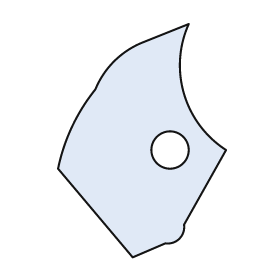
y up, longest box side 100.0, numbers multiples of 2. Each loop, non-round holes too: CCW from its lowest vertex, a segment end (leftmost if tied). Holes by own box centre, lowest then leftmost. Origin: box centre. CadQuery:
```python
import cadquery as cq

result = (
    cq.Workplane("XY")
    .moveTo(-4.0, -50.0)
    .lineTo(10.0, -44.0)
    .threePointArc((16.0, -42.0), (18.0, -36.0))
    .lineTo(36.0, -4.0)
    .threePointArc((18.0, 20.0), (20.0, 50.0))
    .lineTo(0.0, 42.0)
    .threePointArc((-12.0, 34.0), (-20.0, 22.0))
    .threePointArc((-30.0, 6.0), (-36.0, -12.0))
    .close()
    .moveTo(12.0, -4.0)
    .circle(8.0)
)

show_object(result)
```